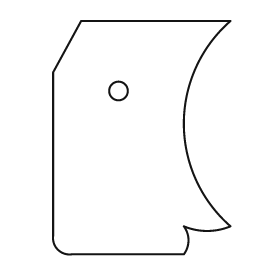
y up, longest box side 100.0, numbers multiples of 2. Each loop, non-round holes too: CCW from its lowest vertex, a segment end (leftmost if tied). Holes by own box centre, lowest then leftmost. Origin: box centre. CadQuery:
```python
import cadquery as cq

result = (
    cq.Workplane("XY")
    .moveTo(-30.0, -50.0)
    .lineTo(18.0, -50.0)
    .threePointArc((20.0, -44.0), (18.0, -38.0))
    .threePointArc((28.0, -40.0), (38.0, -38.0))
    .threePointArc((18.0, 6.0), (38.0, 50.0))
    .lineTo(-26.0, 50.0)
    .lineTo(-38.0, 28.0)
    .lineTo(-38.0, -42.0)
    .threePointArc((-36.0, -48.0), (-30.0, -50.0))
    .close()
    .moveTo(-10.0, 20.0)
    .circle(4.0)
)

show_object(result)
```